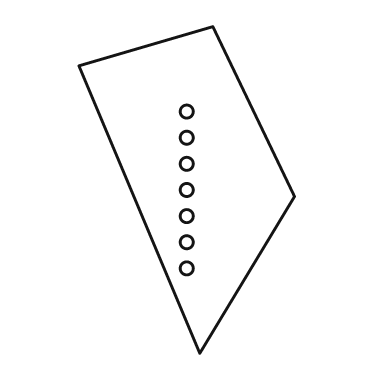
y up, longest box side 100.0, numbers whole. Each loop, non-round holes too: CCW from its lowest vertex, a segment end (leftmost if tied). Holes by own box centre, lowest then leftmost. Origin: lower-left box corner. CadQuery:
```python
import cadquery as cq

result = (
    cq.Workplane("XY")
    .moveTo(37.0, 0.0)
    .lineTo(66.0, 48.0)
    .lineTo(41.0, 100.0)
    .lineTo(0.0, 88.0)
    .close()
    .moveTo(33.0, 26.0)
    .circle(2.0)
    .moveTo(33.0, 34.0)
    .circle(2.0)
    .moveTo(33.0, 42.0)
    .circle(2.0)
    .moveTo(33.0, 50.0)
    .circle(2.0)
    .moveTo(33.0, 58.0)
    .circle(2.0)
    .moveTo(33.0, 66.0)
    .circle(2.0)
    .moveTo(33.0, 74.0)
    .circle(2.0)
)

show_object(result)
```